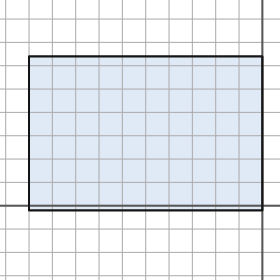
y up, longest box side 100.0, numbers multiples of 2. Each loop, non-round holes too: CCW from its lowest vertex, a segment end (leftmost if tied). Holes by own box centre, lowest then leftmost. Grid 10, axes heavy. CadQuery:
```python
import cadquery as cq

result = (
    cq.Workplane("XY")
    .moveTo(-100.0, -2.0)
    .lineTo(0.0, -2.0)
    .lineTo(0.0, 64.0)
    .lineTo(-100.0, 64.0)
    .close()
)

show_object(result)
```